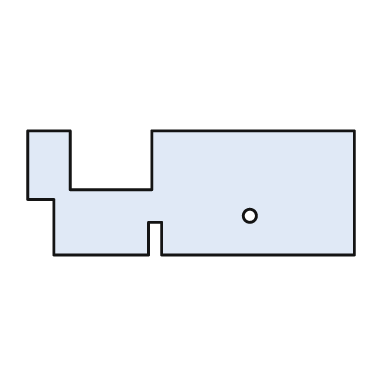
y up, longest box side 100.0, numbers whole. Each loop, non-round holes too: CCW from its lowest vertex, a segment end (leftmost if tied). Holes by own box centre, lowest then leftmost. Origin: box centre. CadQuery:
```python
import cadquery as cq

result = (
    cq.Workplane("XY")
    .moveTo(-42.0, -19.0)
    .lineTo(-13.0, -19.0)
    .lineTo(-13.0, -9.0)
    .lineTo(-9.0, -9.0)
    .lineTo(-9.0, -19.0)
    .lineTo(50.0, -19.0)
    .lineTo(50.0, 19.0)
    .lineTo(-12.0, 19.0)
    .lineTo(-12.0, 1.0)
    .lineTo(-37.0, 1.0)
    .lineTo(-37.0, 19.0)
    .lineTo(-50.0, 19.0)
    .lineTo(-50.0, -2.0)
    .lineTo(-42.0, -2.0)
    .close()
    .moveTo(18.0, -7.0)
    .circle(2.0)
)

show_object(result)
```